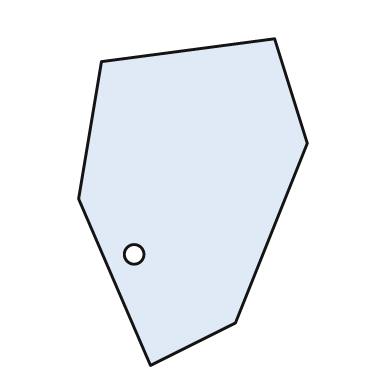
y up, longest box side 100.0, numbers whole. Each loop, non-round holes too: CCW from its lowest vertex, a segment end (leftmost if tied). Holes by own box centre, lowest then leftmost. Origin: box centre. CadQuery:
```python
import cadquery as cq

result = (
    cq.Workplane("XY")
    .moveTo(-13.0, -50.0)
    .lineTo(13.0, -37.0)
    .lineTo(35.0, 18.0)
    .lineTo(25.0, 50.0)
    .lineTo(-28.0, 43.0)
    .lineTo(-35.0, 1.0)
    .close()
    .moveTo(-18.0, -16.0)
    .circle(3.0)
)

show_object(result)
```